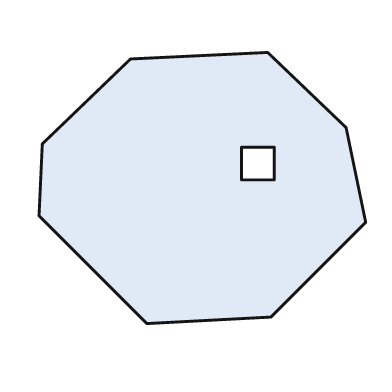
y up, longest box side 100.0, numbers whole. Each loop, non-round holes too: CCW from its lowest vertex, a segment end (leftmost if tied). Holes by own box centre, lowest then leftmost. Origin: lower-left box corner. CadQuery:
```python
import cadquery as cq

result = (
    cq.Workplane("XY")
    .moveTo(33.0, 0.0)
    .lineTo(71.0, 2.0)
    .lineTo(100.0, 31.0)
    .lineTo(94.0, 60.0)
    .lineTo(70.0, 83.0)
    .lineTo(28.0, 81.0)
    .lineTo(1.0, 55.0)
    .lineTo(0.0, 33.0)
    .close()
    .moveTo(62.0, 44.0)
    .lineTo(72.0, 44.0)
    .lineTo(72.0, 54.0)
    .lineTo(62.0, 54.0)
    .close()
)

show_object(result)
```